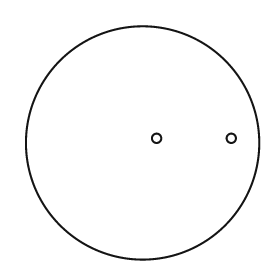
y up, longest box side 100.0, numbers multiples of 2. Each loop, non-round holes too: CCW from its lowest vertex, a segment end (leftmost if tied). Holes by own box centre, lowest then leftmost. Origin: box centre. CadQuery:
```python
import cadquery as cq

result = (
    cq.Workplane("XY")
    .moveTo(0.0, 0.0)
    .circle(50.0)
    .moveTo(6.0, 2.0)
    .circle(2.0)
    .moveTo(38.0, 2.0)
    .circle(2.0)
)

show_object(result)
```